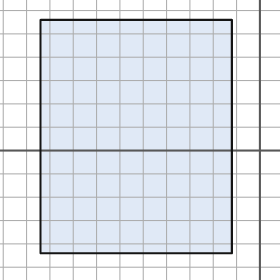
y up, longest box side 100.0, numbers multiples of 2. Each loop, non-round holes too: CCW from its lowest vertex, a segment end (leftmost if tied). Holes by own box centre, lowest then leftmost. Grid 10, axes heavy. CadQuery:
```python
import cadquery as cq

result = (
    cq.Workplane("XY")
    .moveTo(-94.0, -44.0)
    .lineTo(-12.0, -44.0)
    .lineTo(-12.0, 56.0)
    .lineTo(-94.0, 56.0)
    .close()
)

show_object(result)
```